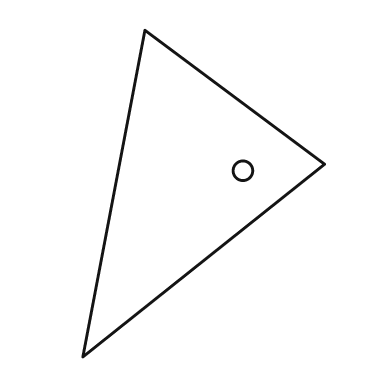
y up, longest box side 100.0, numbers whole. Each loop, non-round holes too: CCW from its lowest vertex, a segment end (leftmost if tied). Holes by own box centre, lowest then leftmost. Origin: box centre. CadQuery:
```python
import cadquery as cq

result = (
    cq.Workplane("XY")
    .moveTo(-37.0, -50.0)
    .lineTo(37.0, 9.0)
    .lineTo(-18.0, 50.0)
    .close()
    .moveTo(12.0, 7.0)
    .circle(3.0)
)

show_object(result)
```